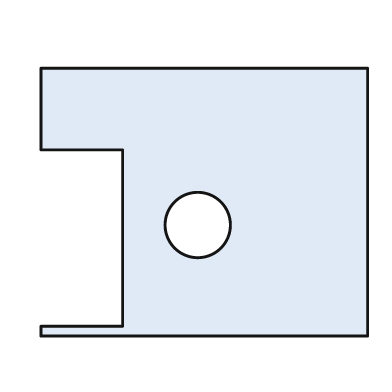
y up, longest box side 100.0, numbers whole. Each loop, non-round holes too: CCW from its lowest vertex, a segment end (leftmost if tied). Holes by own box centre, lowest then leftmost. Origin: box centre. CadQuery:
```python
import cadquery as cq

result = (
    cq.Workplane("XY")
    .moveTo(-50.0, -41.0)
    .lineTo(50.0, -41.0)
    .lineTo(50.0, 41.0)
    .lineTo(-50.0, 41.0)
    .lineTo(-50.0, 16.0)
    .lineTo(-25.0, 16.0)
    .lineTo(-25.0, -38.0)
    .lineTo(-50.0, -38.0)
    .close()
    .moveTo(-2.0, -7.0)
    .circle(10.0)
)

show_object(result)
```